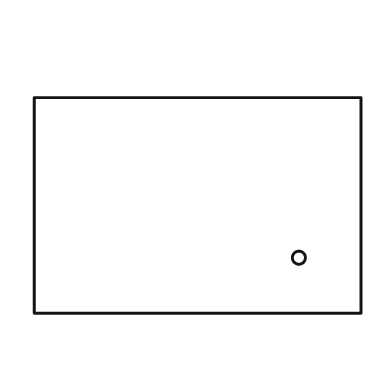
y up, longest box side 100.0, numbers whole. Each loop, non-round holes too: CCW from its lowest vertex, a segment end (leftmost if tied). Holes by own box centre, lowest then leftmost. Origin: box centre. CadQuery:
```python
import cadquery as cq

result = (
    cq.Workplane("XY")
    .moveTo(-50.0, -33.0)
    .lineTo(50.0, -33.0)
    .lineTo(50.0, 33.0)
    .lineTo(-50.0, 33.0)
    .close()
    .moveTo(31.0, -16.0)
    .circle(2.0)
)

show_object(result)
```